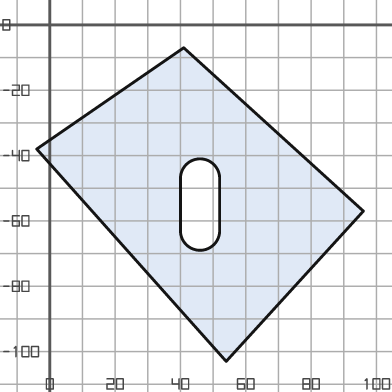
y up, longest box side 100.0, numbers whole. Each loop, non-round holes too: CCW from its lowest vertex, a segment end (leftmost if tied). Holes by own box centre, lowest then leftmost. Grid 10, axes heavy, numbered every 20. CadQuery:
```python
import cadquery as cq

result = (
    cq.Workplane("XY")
    .moveTo(54.0, -103.0)
    .lineTo(96.0, -57.0)
    .lineTo(41.0, -7.0)
    .lineTo(-4.0, -38.0)
    .close()
    .moveTo(40.0, -63.0)
    .threePointArc((46.0, -69.0), (52.0, -63.0))
    .lineTo(52.0, -47.0)
    .threePointArc((46.0, -41.0), (40.0, -47.0))
    .close()
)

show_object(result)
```